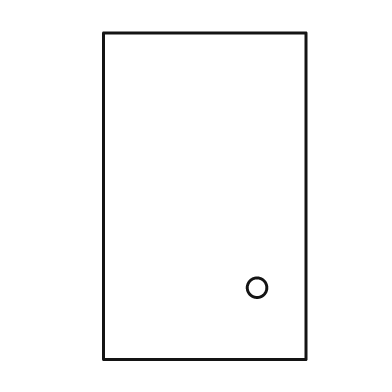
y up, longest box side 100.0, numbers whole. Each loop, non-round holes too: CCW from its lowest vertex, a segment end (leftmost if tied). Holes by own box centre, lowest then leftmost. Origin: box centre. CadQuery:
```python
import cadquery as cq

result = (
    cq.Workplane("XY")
    .moveTo(-31.0, -50.0)
    .lineTo(31.0, -50.0)
    .lineTo(31.0, 50.0)
    .lineTo(-31.0, 50.0)
    .close()
    .moveTo(16.0, -28.0)
    .circle(3.0)
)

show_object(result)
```